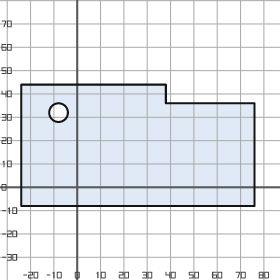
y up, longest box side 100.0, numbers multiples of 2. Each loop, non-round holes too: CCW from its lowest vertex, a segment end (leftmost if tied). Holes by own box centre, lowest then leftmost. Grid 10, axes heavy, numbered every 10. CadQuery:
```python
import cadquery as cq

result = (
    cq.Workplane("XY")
    .moveTo(-24.0, -8.0)
    .lineTo(76.0, -8.0)
    .lineTo(76.0, 36.0)
    .lineTo(38.0, 36.0)
    .lineTo(38.0, 44.0)
    .lineTo(-24.0, 44.0)
    .close()
    .moveTo(-8.0, 32.0)
    .circle(4.0)
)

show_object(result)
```